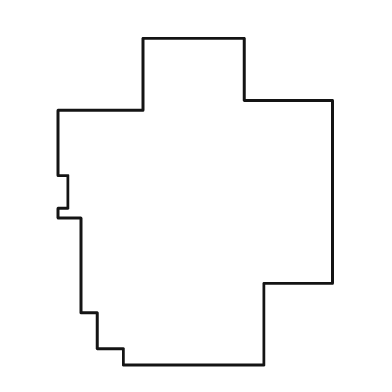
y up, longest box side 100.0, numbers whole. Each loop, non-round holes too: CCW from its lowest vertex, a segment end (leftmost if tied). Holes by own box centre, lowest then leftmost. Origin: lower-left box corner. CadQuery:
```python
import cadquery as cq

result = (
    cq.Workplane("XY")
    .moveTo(20.0, 0.0)
    .lineTo(63.0, 0.0)
    .lineTo(63.0, 25.0)
    .lineTo(84.0, 25.0)
    .lineTo(84.0, 81.0)
    .lineTo(57.0, 81.0)
    .lineTo(57.0, 100.0)
    .lineTo(26.0, 100.0)
    .lineTo(26.0, 78.0)
    .lineTo(0.0, 78.0)
    .lineTo(0.0, 58.0)
    .lineTo(3.0, 58.0)
    .lineTo(3.0, 48.0)
    .lineTo(0.0, 48.0)
    .lineTo(0.0, 45.0)
    .lineTo(7.0, 45.0)
    .lineTo(7.0, 16.0)
    .lineTo(12.0, 16.0)
    .lineTo(12.0, 5.0)
    .lineTo(20.0, 5.0)
    .close()
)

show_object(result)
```